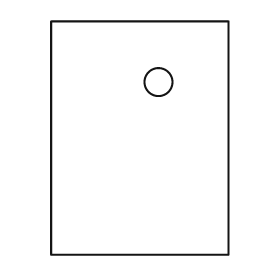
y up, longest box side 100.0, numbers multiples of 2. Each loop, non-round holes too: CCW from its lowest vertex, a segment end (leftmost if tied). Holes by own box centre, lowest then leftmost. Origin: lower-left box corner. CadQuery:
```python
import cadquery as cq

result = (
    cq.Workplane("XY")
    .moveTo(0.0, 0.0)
    .lineTo(76.0, 0.0)
    .lineTo(76.0, 100.0)
    .lineTo(0.0, 100.0)
    .close()
    .moveTo(46.0, 74.0)
    .circle(6.0)
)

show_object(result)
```